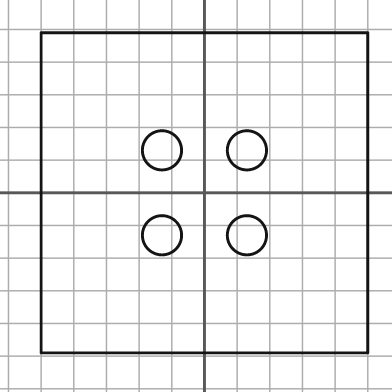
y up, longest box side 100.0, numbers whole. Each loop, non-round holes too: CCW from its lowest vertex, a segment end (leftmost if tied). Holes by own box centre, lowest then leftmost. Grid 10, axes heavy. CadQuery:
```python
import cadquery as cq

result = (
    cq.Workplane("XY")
    .moveTo(-50.0, -49.0)
    .lineTo(50.0, -49.0)
    .lineTo(50.0, 49.0)
    .lineTo(-50.0, 49.0)
    .close()
    .moveTo(-13.0, -13.0)
    .circle(6.0)
    .moveTo(13.0, -13.0)
    .circle(6.0)
    .moveTo(-13.0, 13.0)
    .circle(6.0)
    .moveTo(13.0, 13.0)
    .circle(6.0)
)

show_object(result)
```